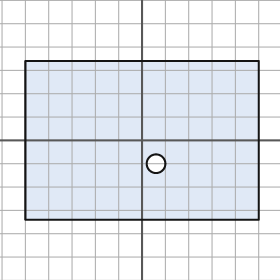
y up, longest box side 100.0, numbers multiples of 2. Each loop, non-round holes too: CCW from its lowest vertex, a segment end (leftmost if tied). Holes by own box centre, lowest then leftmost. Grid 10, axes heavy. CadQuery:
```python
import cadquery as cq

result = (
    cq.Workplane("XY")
    .moveTo(-50.0, -34.0)
    .lineTo(50.0, -34.0)
    .lineTo(50.0, 34.0)
    .lineTo(-50.0, 34.0)
    .close()
    .moveTo(6.0, -10.0)
    .circle(4.0)
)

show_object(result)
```